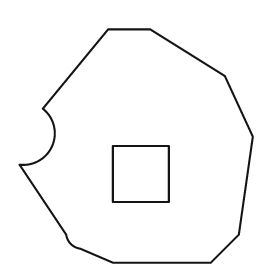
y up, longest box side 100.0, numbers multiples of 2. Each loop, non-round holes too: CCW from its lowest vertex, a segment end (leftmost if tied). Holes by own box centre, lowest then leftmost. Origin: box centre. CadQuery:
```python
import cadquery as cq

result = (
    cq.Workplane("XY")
    .moveTo(-10.0, -50.0)
    .lineTo(32.0, -50.0)
    .lineTo(44.0, -38.0)
    .lineTo(50.0, 4.0)
    .lineTo(38.0, 30.0)
    .lineTo(6.0, 50.0)
    .lineTo(-12.0, 50.0)
    .lineTo(-40.0, 16.0)
    .threePointArc((-36.0, 0.0), (-50.0, -8.0))
    .lineTo(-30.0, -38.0)
    .threePointArc((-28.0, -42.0), (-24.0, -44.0))
    .close()
    .moveTo(-10.0, -24.0)
    .lineTo(14.0, -24.0)
    .lineTo(14.0, 0.0)
    .lineTo(-10.0, 0.0)
    .close()
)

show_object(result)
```